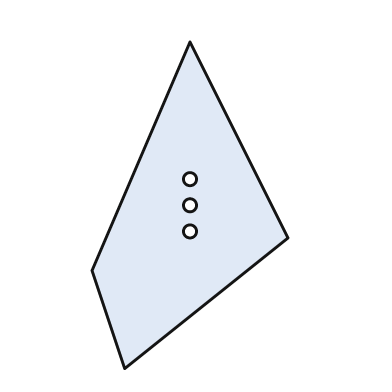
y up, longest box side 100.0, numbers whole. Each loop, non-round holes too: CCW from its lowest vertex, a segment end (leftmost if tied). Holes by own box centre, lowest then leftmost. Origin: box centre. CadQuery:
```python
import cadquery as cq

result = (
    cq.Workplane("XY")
    .moveTo(-20.0, -50.0)
    .lineTo(30.0, -10.0)
    .lineTo(0.0, 50.0)
    .lineTo(-30.0, -20.0)
    .close()
    .moveTo(0.0, -8.0)
    .circle(2.0)
    .moveTo(0.0, 0.0)
    .circle(2.0)
    .moveTo(0.0, 8.0)
    .circle(2.0)
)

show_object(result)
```